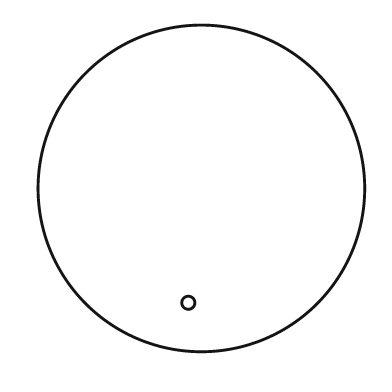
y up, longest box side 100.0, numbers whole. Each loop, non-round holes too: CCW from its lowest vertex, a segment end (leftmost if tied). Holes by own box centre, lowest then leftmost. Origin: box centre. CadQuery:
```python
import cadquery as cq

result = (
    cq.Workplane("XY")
    .moveTo(0.0, 0.0)
    .circle(50.0)
    .moveTo(-4.0, -35.0)
    .circle(2.0)
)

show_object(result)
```